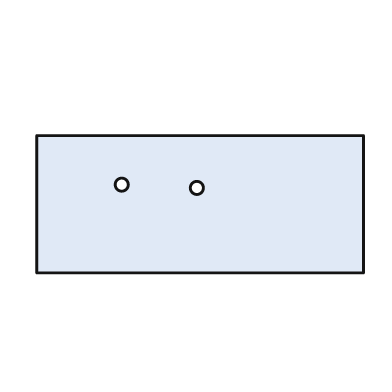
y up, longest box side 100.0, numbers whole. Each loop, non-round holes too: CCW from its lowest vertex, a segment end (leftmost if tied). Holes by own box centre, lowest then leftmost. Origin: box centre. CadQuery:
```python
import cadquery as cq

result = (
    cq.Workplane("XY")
    .moveTo(-50.0, -21.0)
    .lineTo(50.0, -21.0)
    .lineTo(50.0, 21.0)
    .lineTo(-50.0, 21.0)
    .close()
    .moveTo(-1.0, 5.0)
    .circle(2.0)
    .moveTo(-24.0, 6.0)
    .circle(2.0)
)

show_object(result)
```